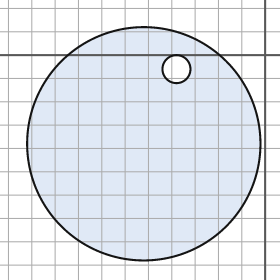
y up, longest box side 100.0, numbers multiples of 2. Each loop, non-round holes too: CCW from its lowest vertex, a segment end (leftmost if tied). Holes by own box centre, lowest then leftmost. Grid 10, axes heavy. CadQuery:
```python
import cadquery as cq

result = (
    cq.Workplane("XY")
    .moveTo(-52.0, -38.0)
    .circle(50.0)
    .moveTo(-38.0, -6.0)
    .circle(6.0)
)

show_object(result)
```